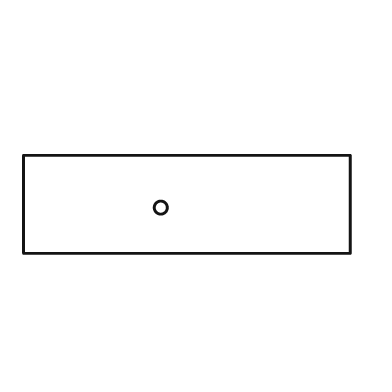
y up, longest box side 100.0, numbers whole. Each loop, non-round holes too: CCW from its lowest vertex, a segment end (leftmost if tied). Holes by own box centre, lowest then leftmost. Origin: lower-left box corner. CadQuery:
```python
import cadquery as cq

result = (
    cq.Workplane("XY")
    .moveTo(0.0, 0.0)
    .lineTo(100.0, 0.0)
    .lineTo(100.0, 30.0)
    .lineTo(0.0, 30.0)
    .close()
    .moveTo(42.0, 14.0)
    .circle(2.0)
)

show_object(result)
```